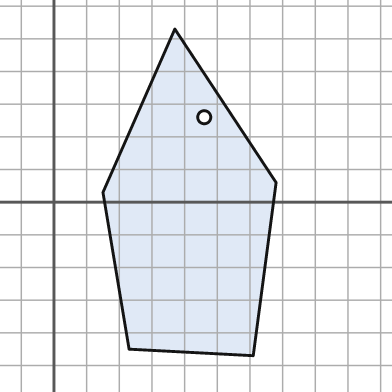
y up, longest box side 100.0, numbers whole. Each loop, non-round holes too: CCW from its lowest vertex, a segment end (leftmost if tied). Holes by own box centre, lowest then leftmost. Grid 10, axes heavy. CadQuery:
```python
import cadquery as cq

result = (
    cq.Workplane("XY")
    .moveTo(61.0, -47.0)
    .lineTo(68.0, 6.0)
    .lineTo(37.0, 53.0)
    .lineTo(15.0, 3.0)
    .lineTo(23.0, -45.0)
    .close()
    .moveTo(46.0, 26.0)
    .circle(2.0)
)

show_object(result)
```